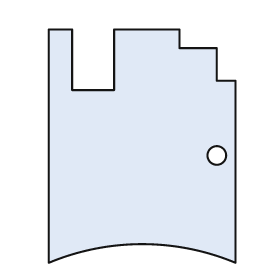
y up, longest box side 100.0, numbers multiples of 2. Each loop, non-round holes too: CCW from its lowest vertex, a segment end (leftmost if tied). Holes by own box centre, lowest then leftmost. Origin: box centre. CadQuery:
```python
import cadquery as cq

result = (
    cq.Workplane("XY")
    .moveTo(-40.0, -50.0)
    .threePointArc((0.0, -42.0), (40.0, -50.0))
    .lineTo(40.0, 28.0)
    .lineTo(32.0, 28.0)
    .lineTo(32.0, 42.0)
    .lineTo(16.0, 42.0)
    .lineTo(16.0, 50.0)
    .lineTo(-12.0, 50.0)
    .lineTo(-12.0, 24.0)
    .lineTo(-30.0, 24.0)
    .lineTo(-30.0, 50.0)
    .lineTo(-40.0, 50.0)
    .close()
    .moveTo(32.0, -4.0)
    .circle(4.0)
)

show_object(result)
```